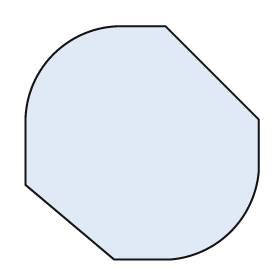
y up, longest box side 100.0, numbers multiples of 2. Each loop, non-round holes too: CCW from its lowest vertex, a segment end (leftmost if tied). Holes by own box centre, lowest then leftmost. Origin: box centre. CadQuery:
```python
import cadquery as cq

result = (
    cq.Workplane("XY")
    .moveTo(-12.0, -50.0)
    .lineTo(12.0, -50.0)
    .threePointArc((38.0, -38.0), (50.0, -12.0))
    .lineTo(50.0, 10.0)
    .lineTo(10.0, 50.0)
    .lineTo(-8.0, 50.0)
    .threePointArc((-38.0, 38.0), (-50.0, 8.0))
    .lineTo(-50.0, -18.0)
    .close()
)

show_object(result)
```